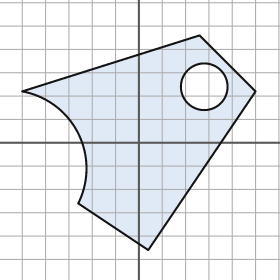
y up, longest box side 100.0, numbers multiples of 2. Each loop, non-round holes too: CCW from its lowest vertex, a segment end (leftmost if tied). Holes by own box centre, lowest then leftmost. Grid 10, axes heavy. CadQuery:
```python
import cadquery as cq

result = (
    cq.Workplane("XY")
    .moveTo(4.0, -46.0)
    .lineTo(50.0, 22.0)
    .lineTo(26.0, 46.0)
    .lineTo(-50.0, 22.0)
    .threePointArc((-26.0, 4.0), (-26.0, -26.0))
    .close()
    .moveTo(28.0, 24.0)
    .circle(10.0)
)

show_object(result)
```